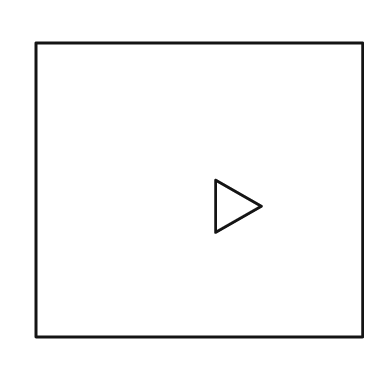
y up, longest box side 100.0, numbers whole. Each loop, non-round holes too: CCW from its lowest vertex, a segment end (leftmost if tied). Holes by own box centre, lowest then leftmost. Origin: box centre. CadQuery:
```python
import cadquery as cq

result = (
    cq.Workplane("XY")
    .moveTo(-50.0, -45.0)
    .lineTo(50.0, -45.0)
    .lineTo(50.0, 45.0)
    .lineTo(-50.0, 45.0)
    .close()
    .moveTo(5.0, -13.0)
    .lineTo(19.0, -5.0)
    .lineTo(5.0, 3.0)
    .close()
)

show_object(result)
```